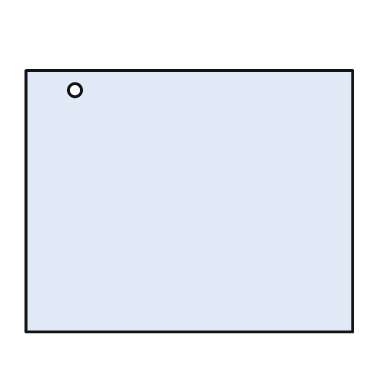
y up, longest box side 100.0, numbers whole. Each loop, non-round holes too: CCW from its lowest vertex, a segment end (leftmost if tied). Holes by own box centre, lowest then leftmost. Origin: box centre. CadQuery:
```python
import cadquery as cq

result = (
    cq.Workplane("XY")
    .moveTo(-50.0, -40.0)
    .lineTo(50.0, -40.0)
    .lineTo(50.0, 40.0)
    .lineTo(-50.0, 40.0)
    .close()
    .moveTo(-35.0, 34.0)
    .circle(2.0)
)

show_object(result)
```